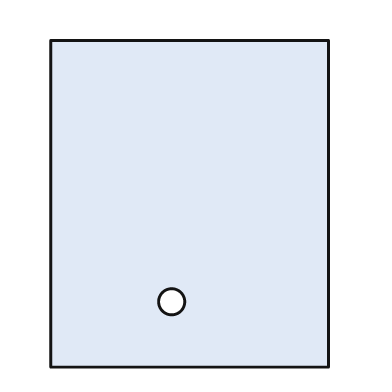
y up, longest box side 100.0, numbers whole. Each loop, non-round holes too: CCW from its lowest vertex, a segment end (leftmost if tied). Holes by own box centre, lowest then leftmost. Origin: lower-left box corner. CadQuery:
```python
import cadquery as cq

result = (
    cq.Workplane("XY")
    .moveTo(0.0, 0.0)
    .lineTo(85.0, 0.0)
    .lineTo(85.0, 100.0)
    .lineTo(0.0, 100.0)
    .close()
    .moveTo(37.0, 20.0)
    .circle(4.0)
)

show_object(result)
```